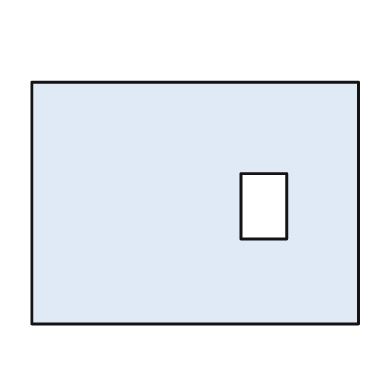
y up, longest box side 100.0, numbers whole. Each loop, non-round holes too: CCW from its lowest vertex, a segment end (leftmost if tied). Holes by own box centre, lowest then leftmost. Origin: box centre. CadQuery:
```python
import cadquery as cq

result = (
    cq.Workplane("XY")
    .moveTo(-50.0, -37.0)
    .lineTo(50.0, -37.0)
    .lineTo(50.0, 37.0)
    .lineTo(-50.0, 37.0)
    .close()
    .moveTo(14.0, -11.0)
    .lineTo(28.0, -11.0)
    .lineTo(28.0, 9.0)
    .lineTo(14.0, 9.0)
    .close()
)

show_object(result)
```